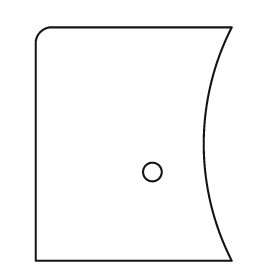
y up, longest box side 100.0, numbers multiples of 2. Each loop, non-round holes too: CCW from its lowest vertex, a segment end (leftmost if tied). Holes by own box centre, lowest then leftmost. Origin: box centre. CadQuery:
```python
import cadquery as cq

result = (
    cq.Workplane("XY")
    .moveTo(-42.0, -50.0)
    .lineTo(42.0, -50.0)
    .threePointArc((30.0, 0.0), (42.0, 50.0))
    .lineTo(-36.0, 50.0)
    .threePointArc((-40.0, 48.0), (-42.0, 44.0))
    .close()
    .moveTo(8.0, -12.0)
    .circle(4.0)
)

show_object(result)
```